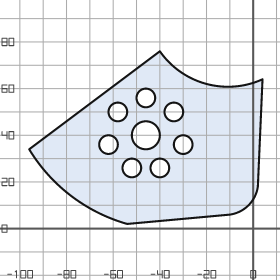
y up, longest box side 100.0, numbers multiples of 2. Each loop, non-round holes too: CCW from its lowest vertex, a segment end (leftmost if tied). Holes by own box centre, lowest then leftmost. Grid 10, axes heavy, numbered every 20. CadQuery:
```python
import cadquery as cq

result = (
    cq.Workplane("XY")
    .moveTo(-54.0, 2.0)
    .lineTo(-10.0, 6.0)
    .threePointArc((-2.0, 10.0), (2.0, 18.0))
    .lineTo(4.0, 64.0)
    .threePointArc((-20.0, 62.0), (-40.0, 76.0))
    .lineTo(-96.0, 34.0)
    .threePointArc((-78.0, 14.0), (-54.0, 2.0))
    .close()
    .moveTo(-52.0, 26.0)
    .circle(4.0)
    .moveTo(-40.0, 26.0)
    .circle(4.0)
    .moveTo(-62.0, 36.0)
    .circle(4.0)
    .moveTo(-30.0, 36.0)
    .circle(4.0)
    .moveTo(-46.0, 40.0)
    .circle(6.0)
    .moveTo(-58.0, 50.0)
    .circle(4.0)
    .moveTo(-34.0, 50.0)
    .circle(4.0)
    .moveTo(-46.0, 56.0)
    .circle(4.0)
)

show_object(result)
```